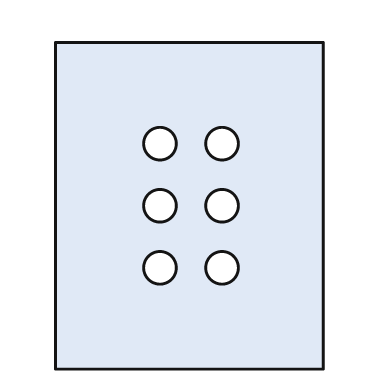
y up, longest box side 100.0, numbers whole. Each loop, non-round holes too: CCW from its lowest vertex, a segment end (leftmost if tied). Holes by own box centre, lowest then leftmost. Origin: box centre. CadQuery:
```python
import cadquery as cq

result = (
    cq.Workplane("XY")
    .moveTo(-41.0, -50.0)
    .lineTo(41.0, -50.0)
    .lineTo(41.0, 50.0)
    .lineTo(-41.0, 50.0)
    .close()
    .moveTo(-9.0, -19.0)
    .circle(5.0)
    .moveTo(10.0, -19.0)
    .circle(5.0)
    .moveTo(-9.0, 0.0)
    .circle(5.0)
    .moveTo(10.0, 0.0)
    .circle(5.0)
    .moveTo(-9.0, 19.0)
    .circle(5.0)
    .moveTo(10.0, 19.0)
    .circle(5.0)
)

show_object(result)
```